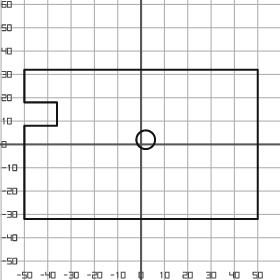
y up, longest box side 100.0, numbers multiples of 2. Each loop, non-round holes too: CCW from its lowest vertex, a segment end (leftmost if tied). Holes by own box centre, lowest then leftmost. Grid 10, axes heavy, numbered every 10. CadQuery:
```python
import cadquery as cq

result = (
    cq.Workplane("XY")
    .moveTo(-50.0, -32.0)
    .lineTo(50.0, -32.0)
    .lineTo(50.0, 32.0)
    .lineTo(-50.0, 32.0)
    .lineTo(-50.0, 18.0)
    .lineTo(-36.0, 18.0)
    .lineTo(-36.0, 8.0)
    .lineTo(-50.0, 8.0)
    .close()
    .moveTo(2.0, 2.0)
    .circle(4.0)
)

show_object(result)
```